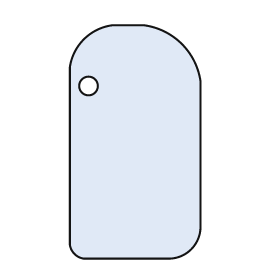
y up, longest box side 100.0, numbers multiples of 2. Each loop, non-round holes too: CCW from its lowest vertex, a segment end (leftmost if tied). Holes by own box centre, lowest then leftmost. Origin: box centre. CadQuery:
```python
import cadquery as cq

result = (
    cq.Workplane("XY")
    .moveTo(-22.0, -50.0)
    .lineTo(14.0, -50.0)
    .threePointArc((24.0, -46.0), (28.0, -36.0))
    .lineTo(28.0, 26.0)
    .threePointArc((20.0, 42.0), (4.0, 50.0))
    .lineTo(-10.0, 50.0)
    .threePointArc((-22.0, 44.0), (-28.0, 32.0))
    .lineTo(-28.0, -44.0)
    .threePointArc((-26.0, -48.0), (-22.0, -50.0))
    .close()
    .moveTo(-20.0, 24.0)
    .circle(4.0)
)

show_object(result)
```